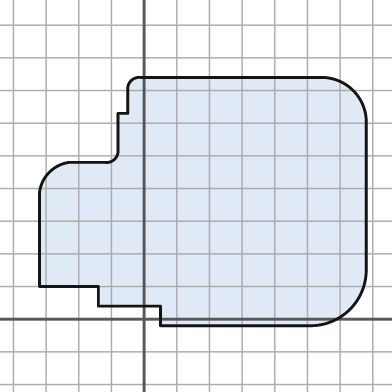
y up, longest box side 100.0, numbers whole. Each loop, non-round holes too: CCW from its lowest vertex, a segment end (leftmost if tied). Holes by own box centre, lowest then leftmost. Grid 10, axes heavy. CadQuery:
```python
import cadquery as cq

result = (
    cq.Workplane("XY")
    .moveTo(5.0, -2.0)
    .lineTo(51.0, -2.0)
    .threePointArc((63.0, 3.0), (68.0, 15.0))
    .lineTo(68.0, 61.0)
    .threePointArc((64.0, 70.0), (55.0, 74.0))
    .lineTo(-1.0, 74.0)
    .threePointArc((-4.0, 73.0), (-5.0, 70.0))
    .lineTo(-5.0, 63.0)
    .lineTo(-8.0, 63.0)
    .lineTo(-8.0, 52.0)
    .threePointArc((-9.0, 49.0), (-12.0, 48.0))
    .lineTo(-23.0, 48.0)
    .threePointArc((-29.0, 45.0), (-32.0, 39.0))
    .lineTo(-32.0, 10.0)
    .lineTo(-14.0, 10.0)
    .lineTo(-14.0, 4.0)
    .lineTo(5.0, 4.0)
    .close()
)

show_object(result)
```